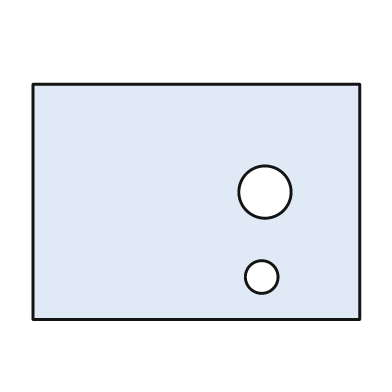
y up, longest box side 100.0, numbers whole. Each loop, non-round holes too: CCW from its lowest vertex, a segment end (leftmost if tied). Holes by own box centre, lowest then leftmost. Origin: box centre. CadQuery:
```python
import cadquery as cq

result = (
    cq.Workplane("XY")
    .moveTo(-50.0, -36.0)
    .lineTo(50.0, -36.0)
    .lineTo(50.0, 36.0)
    .lineTo(-50.0, 36.0)
    .close()
    .moveTo(20.0, -23.0)
    .circle(5.0)
    .moveTo(21.0, 3.0)
    .circle(8.0)
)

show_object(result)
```